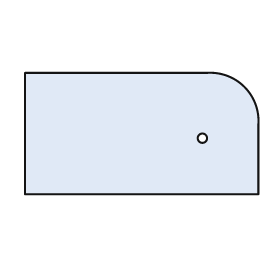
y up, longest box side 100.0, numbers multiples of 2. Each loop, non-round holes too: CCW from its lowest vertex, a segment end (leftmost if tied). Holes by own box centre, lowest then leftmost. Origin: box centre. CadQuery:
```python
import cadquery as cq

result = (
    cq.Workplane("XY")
    .moveTo(-50.0, -26.0)
    .lineTo(50.0, -26.0)
    .lineTo(50.0, 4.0)
    .threePointArc((44.0, 20.0), (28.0, 26.0))
    .lineTo(-50.0, 26.0)
    .close()
    .moveTo(26.0, -2.0)
    .circle(2.0)
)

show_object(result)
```